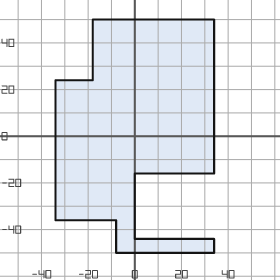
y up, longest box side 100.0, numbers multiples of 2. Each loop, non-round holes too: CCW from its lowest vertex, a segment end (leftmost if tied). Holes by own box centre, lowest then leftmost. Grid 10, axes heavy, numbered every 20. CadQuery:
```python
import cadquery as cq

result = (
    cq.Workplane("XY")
    .moveTo(-8.0, -50.0)
    .lineTo(34.0, -50.0)
    .lineTo(34.0, -44.0)
    .lineTo(0.0, -44.0)
    .lineTo(0.0, -16.0)
    .lineTo(34.0, -16.0)
    .lineTo(34.0, 50.0)
    .lineTo(-18.0, 50.0)
    .lineTo(-18.0, 24.0)
    .lineTo(-34.0, 24.0)
    .lineTo(-34.0, -36.0)
    .lineTo(-8.0, -36.0)
    .close()
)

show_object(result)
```